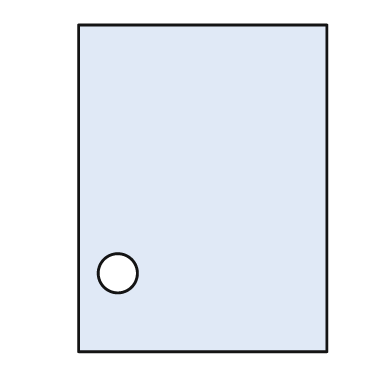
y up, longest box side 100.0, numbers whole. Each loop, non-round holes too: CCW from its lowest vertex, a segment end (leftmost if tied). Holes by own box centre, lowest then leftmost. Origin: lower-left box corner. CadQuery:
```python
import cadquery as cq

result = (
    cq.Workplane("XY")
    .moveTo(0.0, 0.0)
    .lineTo(76.0, 0.0)
    .lineTo(76.0, 100.0)
    .lineTo(0.0, 100.0)
    .close()
    .moveTo(12.0, 24.0)
    .circle(6.0)
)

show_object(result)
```